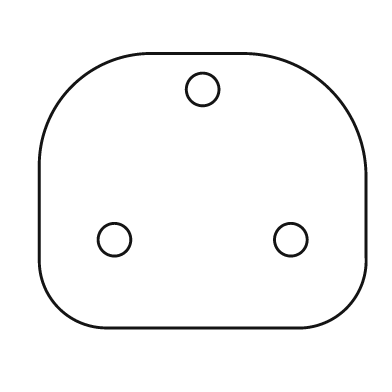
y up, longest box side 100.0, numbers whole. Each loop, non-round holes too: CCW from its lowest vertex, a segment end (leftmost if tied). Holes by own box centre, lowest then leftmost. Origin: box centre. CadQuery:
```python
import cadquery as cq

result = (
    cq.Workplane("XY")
    .moveTo(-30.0, -42.0)
    .lineTo(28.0, -42.0)
    .threePointArc((44.0, -36.0), (50.0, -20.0))
    .lineTo(50.0, 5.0)
    .threePointArc((39.0, 31.0), (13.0, 42.0))
    .lineTo(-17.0, 42.0)
    .threePointArc((-40.0, 32.0), (-50.0, 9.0))
    .lineTo(-50.0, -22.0)
    .threePointArc((-44.0, -36.0), (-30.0, -42.0))
    .close()
    .moveTo(-27.0, -15.0)
    .circle(5.0)
    .moveTo(27.0, -15.0)
    .circle(5.0)
    .moveTo(0.0, 31.0)
    .circle(5.0)
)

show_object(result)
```